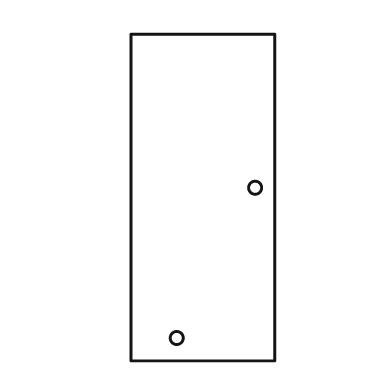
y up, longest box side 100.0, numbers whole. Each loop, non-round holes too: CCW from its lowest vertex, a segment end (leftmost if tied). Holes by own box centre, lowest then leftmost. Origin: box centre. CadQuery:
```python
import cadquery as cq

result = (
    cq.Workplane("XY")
    .moveTo(-22.0, -50.0)
    .lineTo(22.0, -50.0)
    .lineTo(22.0, 50.0)
    .lineTo(-22.0, 50.0)
    .close()
    .moveTo(-8.0, -43.0)
    .circle(2.0)
    .moveTo(16.0, 3.0)
    .circle(2.0)
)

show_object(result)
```